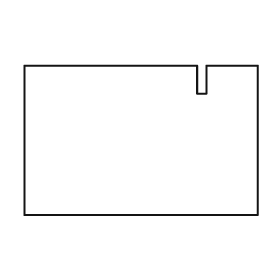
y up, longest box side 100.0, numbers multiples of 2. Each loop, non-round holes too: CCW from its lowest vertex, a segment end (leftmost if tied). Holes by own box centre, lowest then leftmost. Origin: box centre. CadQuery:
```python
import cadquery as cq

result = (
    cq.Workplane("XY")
    .moveTo(-50.0, -32.0)
    .lineTo(50.0, -32.0)
    .lineTo(50.0, 32.0)
    .lineTo(28.0, 32.0)
    .lineTo(28.0, 20.0)
    .lineTo(24.0, 20.0)
    .lineTo(24.0, 32.0)
    .lineTo(-50.0, 32.0)
    .close()
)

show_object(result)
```